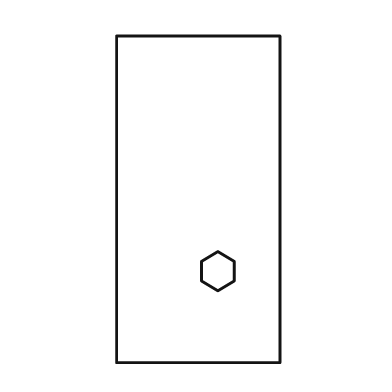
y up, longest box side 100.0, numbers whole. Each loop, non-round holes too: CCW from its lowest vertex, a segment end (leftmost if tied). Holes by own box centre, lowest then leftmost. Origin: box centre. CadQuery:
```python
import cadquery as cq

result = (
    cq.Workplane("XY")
    .moveTo(-25.0, -50.0)
    .lineTo(25.0, -50.0)
    .lineTo(25.0, 50.0)
    .lineTo(-25.0, 50.0)
    .close()
    .moveTo(6.0, -28.0)
    .lineTo(11.0, -25.0)
    .lineTo(11.0, -19.0)
    .lineTo(6.0, -16.0)
    .lineTo(1.0, -19.0)
    .lineTo(1.0, -25.0)
    .close()
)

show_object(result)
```